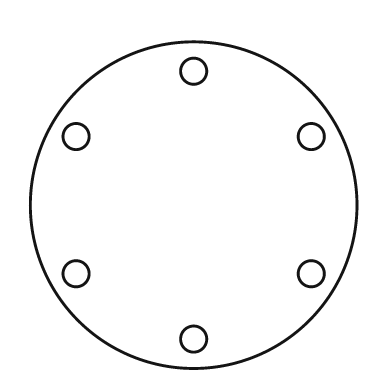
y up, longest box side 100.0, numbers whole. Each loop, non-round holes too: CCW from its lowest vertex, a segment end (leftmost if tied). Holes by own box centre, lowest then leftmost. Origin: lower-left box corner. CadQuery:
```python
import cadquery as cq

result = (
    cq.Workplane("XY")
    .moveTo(50.0, 50.0)
    .circle(50.0)
    .moveTo(50.0, 9.0)
    .circle(4.0)
    .moveTo(14.0, 29.0)
    .circle(4.0)
    .moveTo(86.0, 29.0)
    .circle(4.0)
    .moveTo(14.0, 71.0)
    .circle(4.0)
    .moveTo(86.0, 71.0)
    .circle(4.0)
    .moveTo(50.0, 91.0)
    .circle(4.0)
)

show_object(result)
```